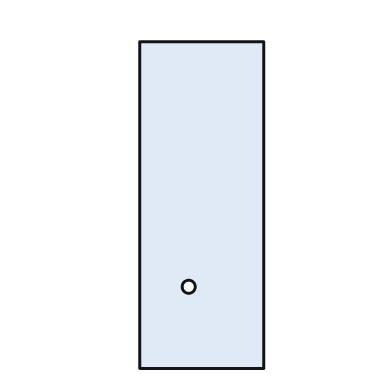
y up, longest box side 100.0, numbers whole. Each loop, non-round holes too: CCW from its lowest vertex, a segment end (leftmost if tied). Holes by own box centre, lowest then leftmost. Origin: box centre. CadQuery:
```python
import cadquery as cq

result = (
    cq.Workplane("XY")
    .moveTo(-19.0, -50.0)
    .lineTo(19.0, -50.0)
    .lineTo(19.0, 50.0)
    .lineTo(-19.0, 50.0)
    .close()
    .moveTo(-4.0, -25.0)
    .circle(2.0)
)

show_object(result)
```